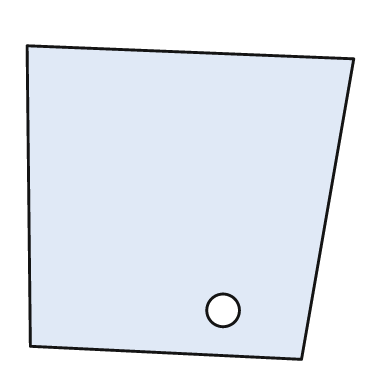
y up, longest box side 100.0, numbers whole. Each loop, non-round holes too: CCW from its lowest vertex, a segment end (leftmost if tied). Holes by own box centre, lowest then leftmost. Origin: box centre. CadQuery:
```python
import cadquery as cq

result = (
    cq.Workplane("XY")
    .moveTo(34.0, -48.0)
    .lineTo(50.0, 44.0)
    .lineTo(-50.0, 48.0)
    .lineTo(-49.0, -44.0)
    .close()
    .moveTo(10.0, -33.0)
    .circle(5.0)
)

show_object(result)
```